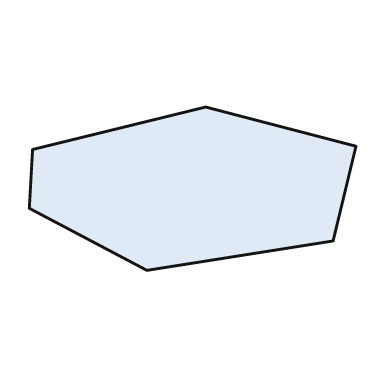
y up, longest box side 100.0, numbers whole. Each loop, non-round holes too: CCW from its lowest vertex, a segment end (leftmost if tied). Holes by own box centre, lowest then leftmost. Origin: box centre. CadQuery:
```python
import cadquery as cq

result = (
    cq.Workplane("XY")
    .moveTo(-14.0, -25.0)
    .lineTo(43.0, -16.0)
    .lineTo(50.0, 13.0)
    .lineTo(4.0, 25.0)
    .lineTo(-49.0, 12.0)
    .lineTo(-50.0, -6.0)
    .close()
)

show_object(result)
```